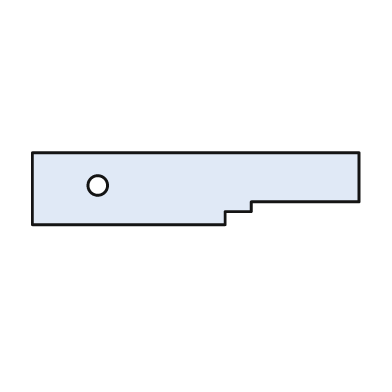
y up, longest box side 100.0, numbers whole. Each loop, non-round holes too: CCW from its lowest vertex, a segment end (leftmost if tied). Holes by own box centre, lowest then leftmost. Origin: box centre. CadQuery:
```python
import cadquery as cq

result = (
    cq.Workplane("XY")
    .moveTo(-50.0, -11.0)
    .lineTo(9.0, -11.0)
    .lineTo(9.0, -7.0)
    .lineTo(17.0, -7.0)
    .lineTo(17.0, -4.0)
    .lineTo(50.0, -4.0)
    .lineTo(50.0, 11.0)
    .lineTo(-50.0, 11.0)
    .close()
    .moveTo(-30.0, 1.0)
    .circle(3.0)
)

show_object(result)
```